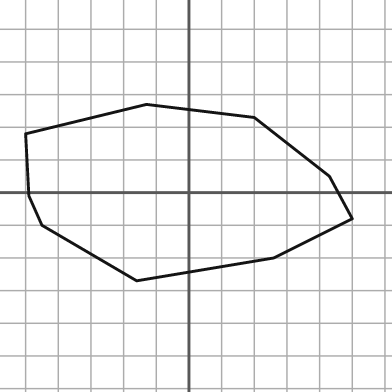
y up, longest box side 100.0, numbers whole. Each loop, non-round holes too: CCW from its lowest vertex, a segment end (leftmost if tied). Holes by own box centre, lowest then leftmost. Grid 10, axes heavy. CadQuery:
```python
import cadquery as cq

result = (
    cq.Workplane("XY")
    .moveTo(-16.0, -27.0)
    .lineTo(26.0, -20.0)
    .lineTo(50.0, -8.0)
    .lineTo(43.0, 5.0)
    .lineTo(20.0, 23.0)
    .lineTo(-13.0, 27.0)
    .lineTo(-50.0, 18.0)
    .lineTo(-49.0, -1.0)
    .lineTo(-45.0, -10.0)
    .close()
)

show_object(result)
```